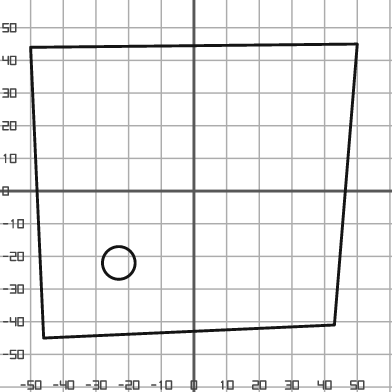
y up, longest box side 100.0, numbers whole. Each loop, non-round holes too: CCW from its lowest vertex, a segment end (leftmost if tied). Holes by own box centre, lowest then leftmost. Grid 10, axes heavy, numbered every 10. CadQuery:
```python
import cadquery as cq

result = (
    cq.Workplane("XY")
    .moveTo(-46.0, -45.0)
    .lineTo(43.0, -41.0)
    .lineTo(50.0, 45.0)
    .lineTo(-50.0, 44.0)
    .close()
    .moveTo(-23.0, -22.0)
    .circle(5.0)
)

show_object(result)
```